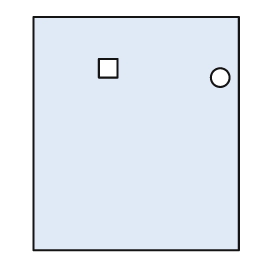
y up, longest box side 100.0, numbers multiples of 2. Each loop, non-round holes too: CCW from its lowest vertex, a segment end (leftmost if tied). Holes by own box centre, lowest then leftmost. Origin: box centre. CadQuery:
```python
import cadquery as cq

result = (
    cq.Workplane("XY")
    .moveTo(-44.0, -50.0)
    .lineTo(44.0, -50.0)
    .lineTo(44.0, 50.0)
    .lineTo(-44.0, 50.0)
    .close()
    .moveTo(36.0, 24.0)
    .circle(4.0)
    .moveTo(-16.0, 24.0)
    .lineTo(-8.0, 24.0)
    .lineTo(-8.0, 32.0)
    .lineTo(-16.0, 32.0)
    .close()
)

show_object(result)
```